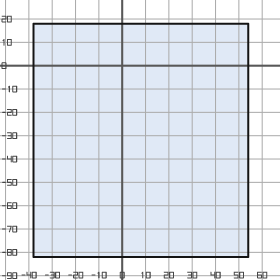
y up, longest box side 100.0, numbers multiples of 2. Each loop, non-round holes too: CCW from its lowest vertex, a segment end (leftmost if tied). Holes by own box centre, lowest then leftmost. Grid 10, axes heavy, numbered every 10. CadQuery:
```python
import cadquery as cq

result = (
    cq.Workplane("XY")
    .moveTo(-38.0, -82.0)
    .lineTo(54.0, -82.0)
    .lineTo(54.0, 18.0)
    .lineTo(-38.0, 18.0)
    .close()
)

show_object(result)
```